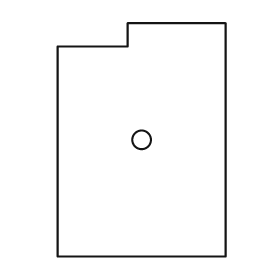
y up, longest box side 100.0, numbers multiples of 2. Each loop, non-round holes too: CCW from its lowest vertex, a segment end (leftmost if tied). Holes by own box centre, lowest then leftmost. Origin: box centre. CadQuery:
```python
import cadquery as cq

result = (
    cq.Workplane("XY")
    .moveTo(-36.0, -50.0)
    .lineTo(36.0, -50.0)
    .lineTo(36.0, 50.0)
    .lineTo(-6.0, 50.0)
    .lineTo(-6.0, 40.0)
    .lineTo(-36.0, 40.0)
    .close()
    .moveTo(0.0, 0.0)
    .circle(4.0)
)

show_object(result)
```